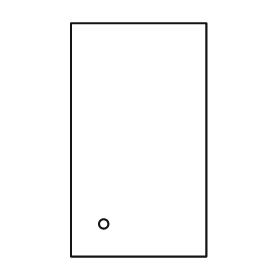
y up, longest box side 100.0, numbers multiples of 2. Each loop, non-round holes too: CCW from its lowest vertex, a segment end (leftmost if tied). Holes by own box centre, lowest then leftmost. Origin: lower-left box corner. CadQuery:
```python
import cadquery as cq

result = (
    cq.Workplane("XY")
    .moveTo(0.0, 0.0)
    .lineTo(58.0, 0.0)
    .lineTo(58.0, 100.0)
    .lineTo(0.0, 100.0)
    .close()
    .moveTo(14.0, 14.0)
    .circle(2.0)
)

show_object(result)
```